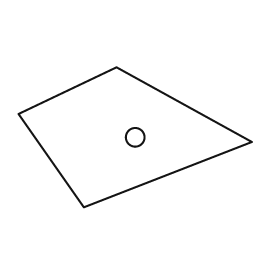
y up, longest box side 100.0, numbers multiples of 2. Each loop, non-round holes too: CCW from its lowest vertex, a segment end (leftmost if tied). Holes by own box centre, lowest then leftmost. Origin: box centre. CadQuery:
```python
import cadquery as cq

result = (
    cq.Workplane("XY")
    .moveTo(-22.0, -30.0)
    .lineTo(50.0, -2.0)
    .lineTo(-8.0, 30.0)
    .lineTo(-50.0, 10.0)
    .close()
    .moveTo(0.0, 0.0)
    .circle(4.0)
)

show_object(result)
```